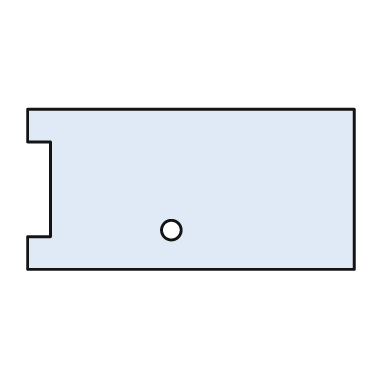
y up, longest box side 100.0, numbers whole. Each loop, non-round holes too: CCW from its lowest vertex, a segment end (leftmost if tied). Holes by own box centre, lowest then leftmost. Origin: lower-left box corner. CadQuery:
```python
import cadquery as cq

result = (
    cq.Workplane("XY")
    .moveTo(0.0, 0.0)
    .lineTo(100.0, 0.0)
    .lineTo(100.0, 49.0)
    .lineTo(0.0, 49.0)
    .lineTo(0.0, 39.0)
    .lineTo(7.0, 39.0)
    .lineTo(7.0, 10.0)
    .lineTo(0.0, 10.0)
    .close()
    .moveTo(44.0, 12.0)
    .circle(3.0)
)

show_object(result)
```